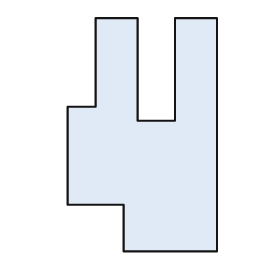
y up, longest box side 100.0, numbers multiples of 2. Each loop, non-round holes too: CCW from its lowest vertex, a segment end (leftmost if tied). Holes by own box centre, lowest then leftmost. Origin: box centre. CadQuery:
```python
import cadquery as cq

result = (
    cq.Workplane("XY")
    .moveTo(-8.0, -50.0)
    .lineTo(32.0, -50.0)
    .lineTo(32.0, 50.0)
    .lineTo(14.0, 50.0)
    .lineTo(14.0, 6.0)
    .lineTo(-2.0, 6.0)
    .lineTo(-2.0, 50.0)
    .lineTo(-20.0, 50.0)
    .lineTo(-20.0, 12.0)
    .lineTo(-32.0, 12.0)
    .lineTo(-32.0, -30.0)
    .lineTo(-8.0, -30.0)
    .close()
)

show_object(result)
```